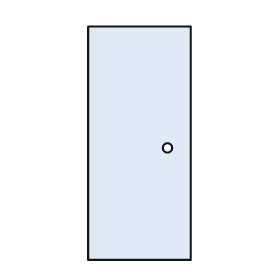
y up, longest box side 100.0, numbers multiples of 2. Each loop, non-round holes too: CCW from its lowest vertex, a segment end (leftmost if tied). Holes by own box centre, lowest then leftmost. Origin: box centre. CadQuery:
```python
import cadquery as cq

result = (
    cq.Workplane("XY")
    .moveTo(-22.0, -50.0)
    .lineTo(22.0, -50.0)
    .lineTo(22.0, 50.0)
    .lineTo(-22.0, 50.0)
    .close()
    .moveTo(12.0, -2.0)
    .circle(2.0)
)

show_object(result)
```